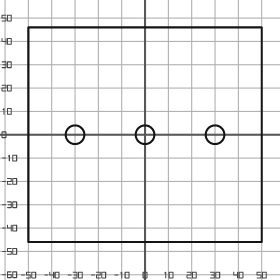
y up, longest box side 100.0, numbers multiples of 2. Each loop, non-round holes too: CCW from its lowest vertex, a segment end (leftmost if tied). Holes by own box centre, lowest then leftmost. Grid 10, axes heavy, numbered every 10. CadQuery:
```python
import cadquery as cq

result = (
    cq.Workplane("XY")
    .moveTo(-50.0, -46.0)
    .lineTo(50.0, -46.0)
    .lineTo(50.0, 46.0)
    .lineTo(-50.0, 46.0)
    .close()
    .moveTo(-30.0, 0.0)
    .circle(4.0)
    .moveTo(0.0, 0.0)
    .circle(4.0)
    .moveTo(30.0, 0.0)
    .circle(4.0)
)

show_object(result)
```